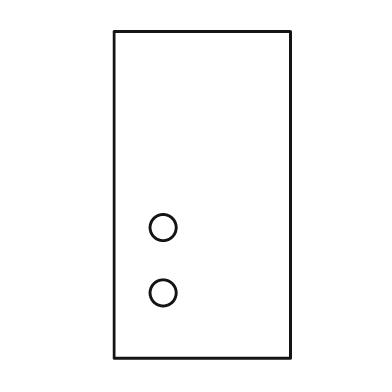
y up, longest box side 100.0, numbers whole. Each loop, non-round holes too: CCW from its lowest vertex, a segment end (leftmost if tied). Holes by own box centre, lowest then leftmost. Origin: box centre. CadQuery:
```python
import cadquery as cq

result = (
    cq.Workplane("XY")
    .moveTo(-27.0, -50.0)
    .lineTo(27.0, -50.0)
    .lineTo(27.0, 50.0)
    .lineTo(-27.0, 50.0)
    .close()
    .moveTo(-12.0, -30.0)
    .circle(4.0)
    .moveTo(-12.0, -10.0)
    .circle(4.0)
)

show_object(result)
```